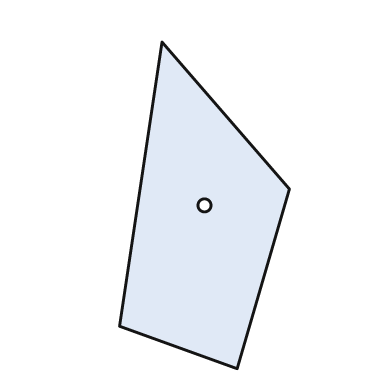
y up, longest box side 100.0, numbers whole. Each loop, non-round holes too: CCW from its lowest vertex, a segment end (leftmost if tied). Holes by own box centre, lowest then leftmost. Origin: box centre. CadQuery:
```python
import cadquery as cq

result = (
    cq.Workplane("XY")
    .moveTo(10.0, -50.0)
    .lineTo(26.0, 5.0)
    .lineTo(-13.0, 50.0)
    .lineTo(-26.0, -37.0)
    .close()
    .moveTo(0.0, 0.0)
    .circle(2.0)
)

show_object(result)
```